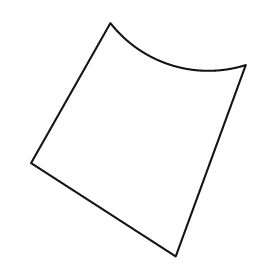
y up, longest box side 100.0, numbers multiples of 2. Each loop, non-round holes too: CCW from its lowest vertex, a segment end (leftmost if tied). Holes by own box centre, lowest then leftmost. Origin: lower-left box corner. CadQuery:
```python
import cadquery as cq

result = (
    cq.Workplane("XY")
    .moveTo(62.0, 0.0)
    .lineTo(92.0, 82.0)
    .threePointArc((60.0, 82.0), (34.0, 100.0))
    .lineTo(0.0, 40.0)
    .close()
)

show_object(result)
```